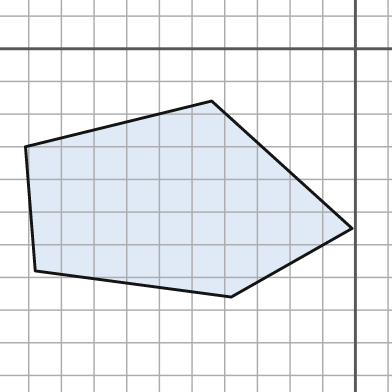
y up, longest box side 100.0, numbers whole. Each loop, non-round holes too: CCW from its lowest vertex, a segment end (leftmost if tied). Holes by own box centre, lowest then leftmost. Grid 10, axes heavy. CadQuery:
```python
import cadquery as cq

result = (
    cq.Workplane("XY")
    .moveTo(-38.0, -76.0)
    .lineTo(-1.0, -55.0)
    .lineTo(-44.0, -16.0)
    .lineTo(-101.0, -30.0)
    .lineTo(-98.0, -68.0)
    .close()
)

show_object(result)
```